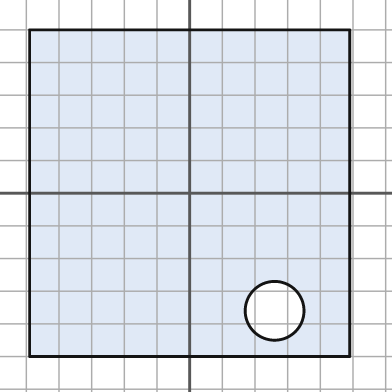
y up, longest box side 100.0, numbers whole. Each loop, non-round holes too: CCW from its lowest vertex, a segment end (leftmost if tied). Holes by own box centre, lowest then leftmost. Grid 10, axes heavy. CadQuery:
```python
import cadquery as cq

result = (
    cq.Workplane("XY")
    .moveTo(-49.0, -50.0)
    .lineTo(49.0, -50.0)
    .lineTo(49.0, 50.0)
    .lineTo(-49.0, 50.0)
    .close()
    .moveTo(26.0, -36.0)
    .circle(9.0)
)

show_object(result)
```